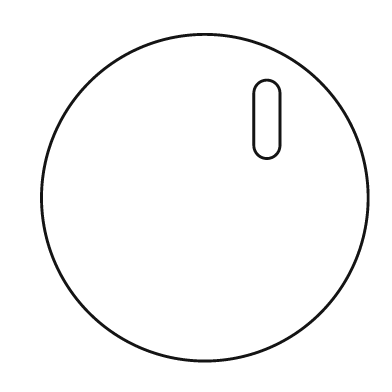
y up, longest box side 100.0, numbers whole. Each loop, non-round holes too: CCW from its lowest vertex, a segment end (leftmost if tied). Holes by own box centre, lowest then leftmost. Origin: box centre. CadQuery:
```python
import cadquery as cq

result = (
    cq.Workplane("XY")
    .moveTo(0.0, 0.0)
    .circle(50.0)
    .moveTo(15.0, 16.0)
    .threePointArc((19.0, 12.0), (23.0, 16.0))
    .lineTo(23.0, 32.0)
    .threePointArc((19.0, 36.0), (15.0, 32.0))
    .close()
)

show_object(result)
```